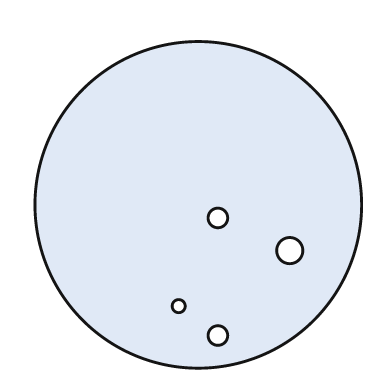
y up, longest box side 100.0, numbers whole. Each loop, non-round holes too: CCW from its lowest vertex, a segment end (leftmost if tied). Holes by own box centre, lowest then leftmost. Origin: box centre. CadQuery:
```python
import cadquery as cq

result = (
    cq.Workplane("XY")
    .moveTo(0.0, 0.0)
    .circle(50.0)
    .moveTo(6.0, -40.0)
    .circle(3.0)
    .moveTo(-6.0, -31.0)
    .circle(2.0)
    .moveTo(28.0, -14.0)
    .circle(4.0)
    .moveTo(6.0, -4.0)
    .circle(3.0)
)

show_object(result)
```